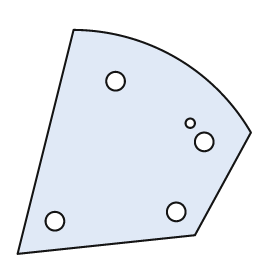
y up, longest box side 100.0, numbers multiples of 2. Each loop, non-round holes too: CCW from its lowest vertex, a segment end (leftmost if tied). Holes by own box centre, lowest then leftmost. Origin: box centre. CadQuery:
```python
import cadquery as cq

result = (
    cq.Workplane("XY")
    .moveTo(-50.0, -48.0)
    .lineTo(26.0, -40.0)
    .lineTo(50.0, 4.0)
    .threePointArc((18.0, 36.0), (-26.0, 48.0))
    .close()
    .moveTo(-34.0, -34.0)
    .circle(4.0)
    .moveTo(18.0, -30.0)
    .circle(4.0)
    .moveTo(30.0, 0.0)
    .circle(4.0)
    .moveTo(24.0, 8.0)
    .circle(2.0)
    .moveTo(-8.0, 26.0)
    .circle(4.0)
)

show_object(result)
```